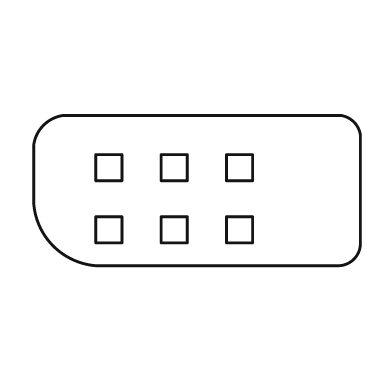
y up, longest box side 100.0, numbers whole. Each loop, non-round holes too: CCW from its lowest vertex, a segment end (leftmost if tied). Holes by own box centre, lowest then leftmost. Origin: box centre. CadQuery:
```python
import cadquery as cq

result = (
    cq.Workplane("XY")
    .moveTo(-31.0, -23.0)
    .lineTo(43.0, -23.0)
    .threePointArc((48.0, -21.0), (50.0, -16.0))
    .lineTo(50.0, 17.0)
    .threePointArc((48.0, 21.0), (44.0, 23.0))
    .lineTo(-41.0, 23.0)
    .threePointArc((-47.0, 20.0), (-50.0, 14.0))
    .lineTo(-50.0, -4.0)
    .threePointArc((-44.0, -17.0), (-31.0, -23.0))
    .close()
    .moveTo(-31.0, -16.0)
    .lineTo(-23.0, -16.0)
    .lineTo(-23.0, -8.0)
    .lineTo(-31.0, -8.0)
    .close()
    .moveTo(-11.0, -16.0)
    .lineTo(-3.0, -16.0)
    .lineTo(-3.0, -8.0)
    .lineTo(-11.0, -8.0)
    .close()
    .moveTo(9.0, -16.0)
    .lineTo(17.0, -16.0)
    .lineTo(17.0, -8.0)
    .lineTo(9.0, -8.0)
    .close()
    .moveTo(-31.0, 3.0)
    .lineTo(-23.0, 3.0)
    .lineTo(-23.0, 11.0)
    .lineTo(-31.0, 11.0)
    .close()
    .moveTo(-11.0, 3.0)
    .lineTo(-3.0, 3.0)
    .lineTo(-3.0, 11.0)
    .lineTo(-11.0, 11.0)
    .close()
    .moveTo(9.0, 3.0)
    .lineTo(17.0, 3.0)
    .lineTo(17.0, 11.0)
    .lineTo(9.0, 11.0)
    .close()
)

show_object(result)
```